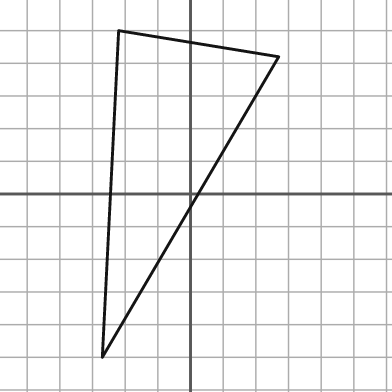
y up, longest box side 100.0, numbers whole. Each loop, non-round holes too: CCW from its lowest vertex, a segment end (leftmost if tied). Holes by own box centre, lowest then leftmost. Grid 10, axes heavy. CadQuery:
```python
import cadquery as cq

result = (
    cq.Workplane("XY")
    .moveTo(-27.0, -50.0)
    .lineTo(27.0, 42.0)
    .lineTo(-22.0, 50.0)
    .close()
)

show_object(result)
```